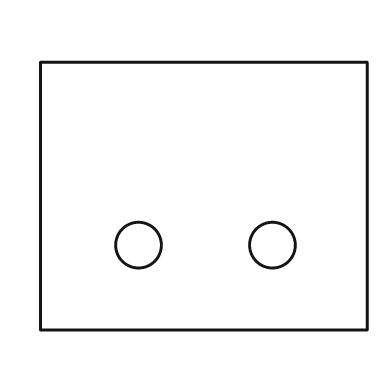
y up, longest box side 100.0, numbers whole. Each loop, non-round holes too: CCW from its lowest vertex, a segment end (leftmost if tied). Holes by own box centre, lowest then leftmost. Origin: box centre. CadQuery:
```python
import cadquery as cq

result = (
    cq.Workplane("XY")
    .moveTo(-50.0, -41.0)
    .lineTo(50.0, -41.0)
    .lineTo(50.0, 41.0)
    .lineTo(-50.0, 41.0)
    .close()
    .moveTo(-20.0, -15.0)
    .circle(7.0)
    .moveTo(21.0, -15.0)
    .circle(7.0)
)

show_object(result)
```